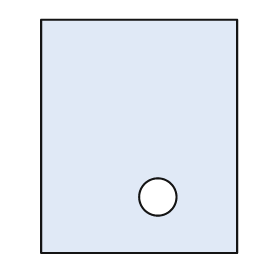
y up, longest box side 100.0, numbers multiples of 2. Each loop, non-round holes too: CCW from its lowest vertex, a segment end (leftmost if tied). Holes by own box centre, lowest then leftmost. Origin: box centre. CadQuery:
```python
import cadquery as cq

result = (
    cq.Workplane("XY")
    .moveTo(-42.0, -50.0)
    .lineTo(42.0, -50.0)
    .lineTo(42.0, 50.0)
    .lineTo(-42.0, 50.0)
    .close()
    .moveTo(8.0, -26.0)
    .circle(8.0)
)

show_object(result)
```